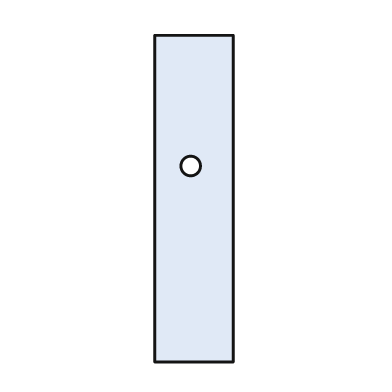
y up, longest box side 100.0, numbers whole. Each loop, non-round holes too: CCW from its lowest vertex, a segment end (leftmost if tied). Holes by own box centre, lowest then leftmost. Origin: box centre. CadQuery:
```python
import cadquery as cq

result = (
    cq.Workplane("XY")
    .moveTo(-12.0, -50.0)
    .lineTo(12.0, -50.0)
    .lineTo(12.0, 50.0)
    .lineTo(-12.0, 50.0)
    .close()
    .moveTo(-1.0, 10.0)
    .circle(3.0)
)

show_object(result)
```